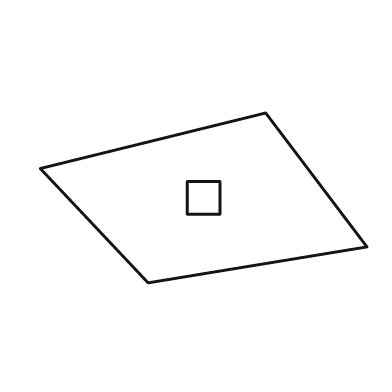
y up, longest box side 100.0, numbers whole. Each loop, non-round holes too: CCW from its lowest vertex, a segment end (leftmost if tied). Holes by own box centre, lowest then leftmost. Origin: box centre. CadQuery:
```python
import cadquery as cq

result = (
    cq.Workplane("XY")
    .moveTo(-17.0, -26.0)
    .lineTo(50.0, -15.0)
    .lineTo(19.0, 26.0)
    .lineTo(-50.0, 9.0)
    .close()
    .moveTo(-5.0, -5.0)
    .lineTo(5.0, -5.0)
    .lineTo(5.0, 5.0)
    .lineTo(-5.0, 5.0)
    .close()
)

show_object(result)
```